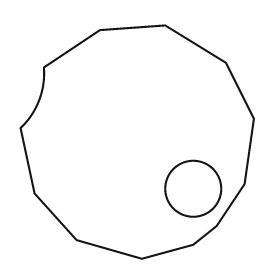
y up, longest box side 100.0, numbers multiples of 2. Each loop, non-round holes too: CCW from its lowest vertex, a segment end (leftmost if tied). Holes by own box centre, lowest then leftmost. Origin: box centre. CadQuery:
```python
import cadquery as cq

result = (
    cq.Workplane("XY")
    .moveTo(2.0, -50.0)
    .lineTo(24.0, -44.0)
    .lineTo(34.0, -36.0)
    .lineTo(46.0, -18.0)
    .lineTo(50.0, 10.0)
    .lineTo(38.0, 34.0)
    .lineTo(12.0, 50.0)
    .lineTo(-16.0, 48.0)
    .lineTo(-40.0, 32.0)
    .threePointArc((-42.0, 18.0), (-50.0, 6.0))
    .lineTo(-44.0, -22.0)
    .lineTo(-26.0, -42.0)
    .close()
    .moveTo(24.0, -20.0)
    .circle(12.0)
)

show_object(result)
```